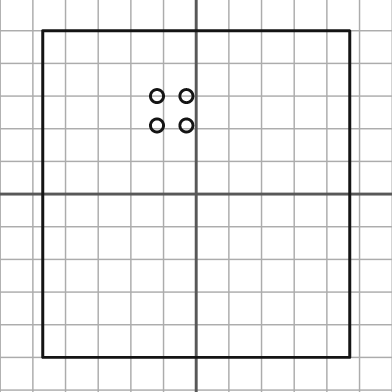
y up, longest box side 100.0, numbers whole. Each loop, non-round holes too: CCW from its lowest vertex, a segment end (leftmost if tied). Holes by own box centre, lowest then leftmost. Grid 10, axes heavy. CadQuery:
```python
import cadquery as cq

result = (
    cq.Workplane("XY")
    .moveTo(-47.0, -50.0)
    .lineTo(47.0, -50.0)
    .lineTo(47.0, 50.0)
    .lineTo(-47.0, 50.0)
    .close()
    .moveTo(-12.0, 21.0)
    .circle(2.0)
    .moveTo(-3.0, 21.0)
    .circle(2.0)
    .moveTo(-12.0, 30.0)
    .circle(2.0)
    .moveTo(-3.0, 30.0)
    .circle(2.0)
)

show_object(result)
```